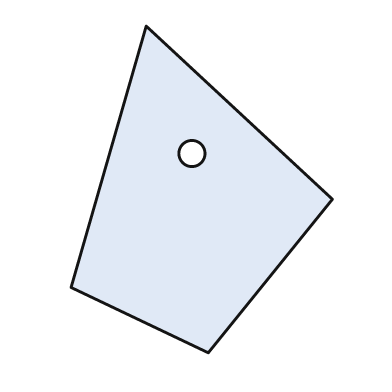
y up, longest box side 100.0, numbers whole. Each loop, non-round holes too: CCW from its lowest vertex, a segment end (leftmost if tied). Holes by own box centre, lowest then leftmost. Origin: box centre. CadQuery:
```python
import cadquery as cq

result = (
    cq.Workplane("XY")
    .moveTo(2.0, -50.0)
    .lineTo(40.0, -3.0)
    .lineTo(-17.0, 50.0)
    .lineTo(-40.0, -30.0)
    .close()
    .moveTo(-3.0, 11.0)
    .circle(4.0)
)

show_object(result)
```